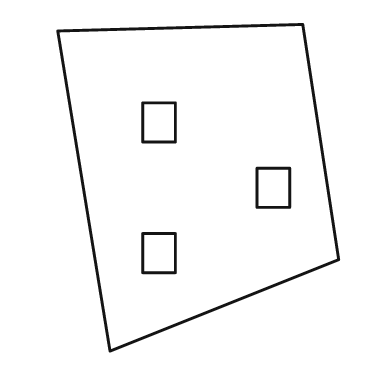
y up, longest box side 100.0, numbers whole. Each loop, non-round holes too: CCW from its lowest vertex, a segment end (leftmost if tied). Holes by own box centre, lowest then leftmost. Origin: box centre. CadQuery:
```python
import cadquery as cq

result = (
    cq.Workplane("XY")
    .moveTo(-27.0, -50.0)
    .lineTo(43.0, -22.0)
    .lineTo(32.0, 50.0)
    .lineTo(-43.0, 48.0)
    .close()
    .moveTo(-17.0, -26.0)
    .lineTo(-7.0, -26.0)
    .lineTo(-7.0, -14.0)
    .lineTo(-17.0, -14.0)
    .close()
    .moveTo(18.0, -6.0)
    .lineTo(28.0, -6.0)
    .lineTo(28.0, 6.0)
    .lineTo(18.0, 6.0)
    .close()
    .moveTo(-17.0, 14.0)
    .lineTo(-7.0, 14.0)
    .lineTo(-7.0, 26.0)
    .lineTo(-17.0, 26.0)
    .close()
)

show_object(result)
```